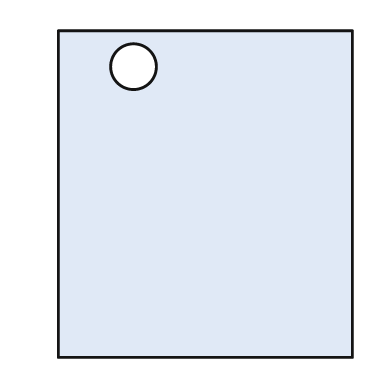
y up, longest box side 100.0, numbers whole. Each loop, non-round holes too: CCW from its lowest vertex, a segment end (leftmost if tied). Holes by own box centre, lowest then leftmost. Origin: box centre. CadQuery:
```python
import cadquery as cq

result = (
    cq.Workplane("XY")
    .moveTo(-45.0, -50.0)
    .lineTo(45.0, -50.0)
    .lineTo(45.0, 50.0)
    .lineTo(-45.0, 50.0)
    .close()
    .moveTo(-22.0, 39.0)
    .circle(7.0)
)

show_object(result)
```